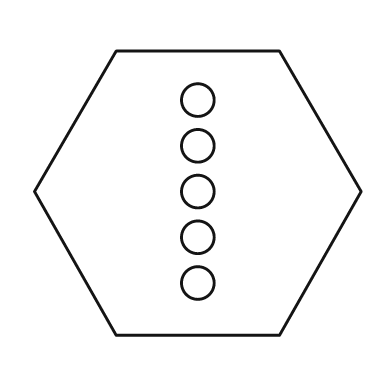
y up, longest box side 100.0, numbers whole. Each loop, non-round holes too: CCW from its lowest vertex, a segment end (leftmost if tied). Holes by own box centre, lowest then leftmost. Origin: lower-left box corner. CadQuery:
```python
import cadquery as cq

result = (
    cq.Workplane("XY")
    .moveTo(25.0, 0.0)
    .lineTo(75.0, 0.0)
    .lineTo(100.0, 44.0)
    .lineTo(75.0, 87.0)
    .lineTo(25.0, 87.0)
    .lineTo(0.0, 44.0)
    .close()
    .moveTo(50.0, 16.0)
    .circle(5.0)
    .moveTo(50.0, 30.0)
    .circle(5.0)
    .moveTo(50.0, 44.0)
    .circle(5.0)
    .moveTo(50.0, 58.0)
    .circle(5.0)
    .moveTo(50.0, 72.0)
    .circle(5.0)
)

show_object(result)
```